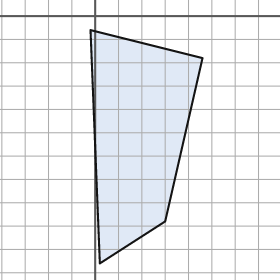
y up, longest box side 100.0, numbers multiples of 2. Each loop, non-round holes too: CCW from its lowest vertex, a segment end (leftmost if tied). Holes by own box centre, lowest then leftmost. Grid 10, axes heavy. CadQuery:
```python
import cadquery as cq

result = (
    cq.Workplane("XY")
    .moveTo(2.0, -106.0)
    .lineTo(30.0, -88.0)
    .lineTo(46.0, -18.0)
    .lineTo(-2.0, -6.0)
    .close()
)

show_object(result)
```